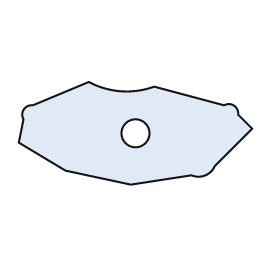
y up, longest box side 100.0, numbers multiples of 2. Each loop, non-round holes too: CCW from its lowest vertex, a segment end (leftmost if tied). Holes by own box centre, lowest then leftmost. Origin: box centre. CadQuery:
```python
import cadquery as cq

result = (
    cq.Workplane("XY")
    .moveTo(-2.0, -22.0)
    .lineTo(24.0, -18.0)
    .threePointArc((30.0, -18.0), (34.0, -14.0))
    .lineTo(50.0, 2.0)
    .lineTo(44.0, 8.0)
    .threePointArc((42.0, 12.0), (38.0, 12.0))
    .lineTo(8.0, 20.0)
    .threePointArc((-6.0, 18.0), (-20.0, 22.0))
    .lineTo(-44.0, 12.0)
    .threePointArc((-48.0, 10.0), (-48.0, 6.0))
    .lineTo(-50.0, -4.0)
    .lineTo(-30.0, -16.0)
    .close()
    .moveTo(0.0, 0.0)
    .circle(6.0)
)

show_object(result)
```